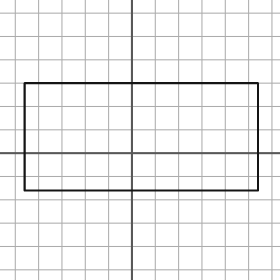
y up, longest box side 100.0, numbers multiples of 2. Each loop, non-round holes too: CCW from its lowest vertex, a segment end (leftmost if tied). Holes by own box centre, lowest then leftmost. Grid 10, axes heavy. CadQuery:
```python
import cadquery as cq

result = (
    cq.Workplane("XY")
    .moveTo(-46.0, -16.0)
    .lineTo(54.0, -16.0)
    .lineTo(54.0, 30.0)
    .lineTo(-46.0, 30.0)
    .close()
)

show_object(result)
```